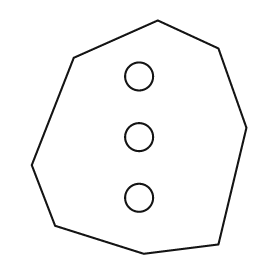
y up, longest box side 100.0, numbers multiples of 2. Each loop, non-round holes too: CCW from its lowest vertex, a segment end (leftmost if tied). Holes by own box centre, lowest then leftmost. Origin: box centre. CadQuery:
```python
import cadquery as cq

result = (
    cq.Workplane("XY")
    .moveTo(2.0, -50.0)
    .lineTo(34.0, -46.0)
    .lineTo(46.0, 4.0)
    .lineTo(34.0, 38.0)
    .lineTo(8.0, 50.0)
    .lineTo(-28.0, 34.0)
    .lineTo(-46.0, -12.0)
    .lineTo(-36.0, -38.0)
    .close()
    .moveTo(0.0, -26.0)
    .circle(6.0)
    .moveTo(0.0, 0.0)
    .circle(6.0)
    .moveTo(0.0, 26.0)
    .circle(6.0)
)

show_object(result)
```